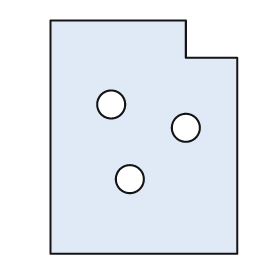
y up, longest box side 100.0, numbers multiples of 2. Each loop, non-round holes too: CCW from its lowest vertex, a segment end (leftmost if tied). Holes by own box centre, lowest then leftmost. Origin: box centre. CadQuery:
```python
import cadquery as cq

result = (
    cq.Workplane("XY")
    .moveTo(-40.0, -50.0)
    .lineTo(40.0, -50.0)
    .lineTo(40.0, 34.0)
    .lineTo(18.0, 34.0)
    .lineTo(18.0, 50.0)
    .lineTo(-40.0, 50.0)
    .close()
    .moveTo(-6.0, -18.0)
    .circle(6.0)
    .moveTo(18.0, 4.0)
    .circle(6.0)
    .moveTo(-14.0, 14.0)
    .circle(6.0)
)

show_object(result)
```